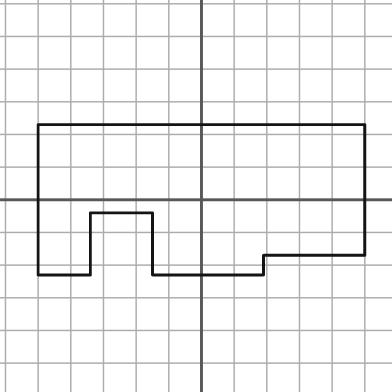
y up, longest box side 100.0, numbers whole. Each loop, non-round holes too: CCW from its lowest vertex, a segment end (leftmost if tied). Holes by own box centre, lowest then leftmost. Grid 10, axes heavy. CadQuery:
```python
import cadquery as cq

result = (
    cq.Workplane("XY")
    .moveTo(-50.0, -23.0)
    .lineTo(-34.0, -23.0)
    .lineTo(-34.0, -4.0)
    .lineTo(-15.0, -4.0)
    .lineTo(-15.0, -23.0)
    .lineTo(19.0, -23.0)
    .lineTo(19.0, -17.0)
    .lineTo(50.0, -17.0)
    .lineTo(50.0, 23.0)
    .lineTo(-50.0, 23.0)
    .close()
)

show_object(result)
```